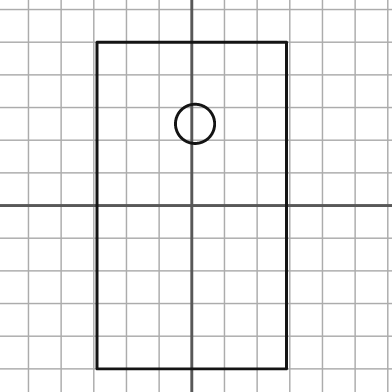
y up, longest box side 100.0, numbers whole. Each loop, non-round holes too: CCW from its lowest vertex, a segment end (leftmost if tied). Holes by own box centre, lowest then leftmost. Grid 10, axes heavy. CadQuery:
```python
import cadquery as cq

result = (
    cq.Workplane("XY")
    .moveTo(-29.0, -50.0)
    .lineTo(29.0, -50.0)
    .lineTo(29.0, 50.0)
    .lineTo(-29.0, 50.0)
    .close()
    .moveTo(1.0, 25.0)
    .circle(6.0)
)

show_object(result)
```